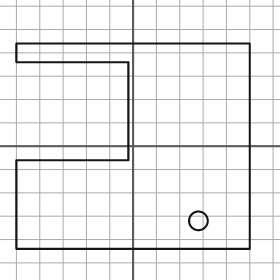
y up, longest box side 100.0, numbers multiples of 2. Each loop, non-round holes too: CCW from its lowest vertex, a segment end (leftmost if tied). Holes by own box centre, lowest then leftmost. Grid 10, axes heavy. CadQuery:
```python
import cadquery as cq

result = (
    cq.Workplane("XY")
    .moveTo(-50.0, -44.0)
    .lineTo(50.0, -44.0)
    .lineTo(50.0, 44.0)
    .lineTo(-50.0, 44.0)
    .lineTo(-50.0, 36.0)
    .lineTo(-2.0, 36.0)
    .lineTo(-2.0, -6.0)
    .lineTo(-50.0, -6.0)
    .close()
    .moveTo(28.0, -32.0)
    .circle(4.0)
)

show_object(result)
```